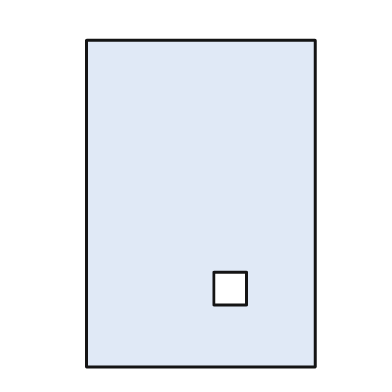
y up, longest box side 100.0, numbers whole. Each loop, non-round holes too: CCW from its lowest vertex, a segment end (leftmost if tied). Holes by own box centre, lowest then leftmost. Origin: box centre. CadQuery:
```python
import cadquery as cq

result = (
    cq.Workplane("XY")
    .moveTo(-35.0, -50.0)
    .lineTo(35.0, -50.0)
    .lineTo(35.0, 50.0)
    .lineTo(-35.0, 50.0)
    .close()
    .moveTo(4.0, -31.0)
    .lineTo(14.0, -31.0)
    .lineTo(14.0, -21.0)
    .lineTo(4.0, -21.0)
    .close()
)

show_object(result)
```